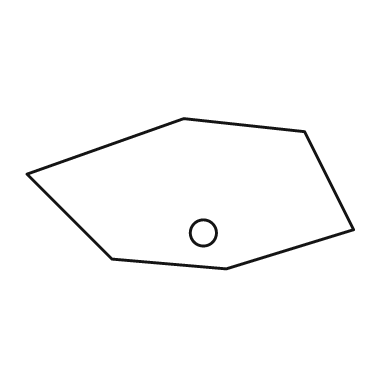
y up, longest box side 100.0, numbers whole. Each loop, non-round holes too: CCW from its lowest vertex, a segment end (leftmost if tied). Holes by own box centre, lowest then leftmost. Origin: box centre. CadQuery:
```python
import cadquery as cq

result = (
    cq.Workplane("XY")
    .moveTo(11.0, -23.0)
    .lineTo(50.0, -11.0)
    .lineTo(35.0, 19.0)
    .lineTo(-2.0, 23.0)
    .lineTo(-50.0, 6.0)
    .lineTo(-24.0, -20.0)
    .close()
    .moveTo(4.0, -12.0)
    .circle(4.0)
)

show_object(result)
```